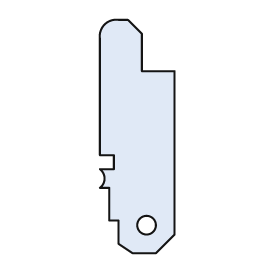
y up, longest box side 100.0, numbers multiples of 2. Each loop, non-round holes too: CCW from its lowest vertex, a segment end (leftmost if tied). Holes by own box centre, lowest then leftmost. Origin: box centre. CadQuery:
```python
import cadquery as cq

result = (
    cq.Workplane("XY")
    .moveTo(-2.0, -50.0)
    .lineTo(8.0, -50.0)
    .lineTo(16.0, -42.0)
    .lineTo(16.0, 28.0)
    .lineTo(2.0, 28.0)
    .lineTo(2.0, 44.0)
    .lineTo(-4.0, 50.0)
    .lineTo(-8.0, 50.0)
    .threePointArc((-14.0, 48.0), (-16.0, 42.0))
    .lineTo(-16.0, -8.0)
    .lineTo(-10.0, -8.0)
    .lineTo(-10.0, -14.0)
    .lineTo(-16.0, -14.0)
    .threePointArc((-14.0, -18.0), (-16.0, -22.0))
    .lineTo(-12.0, -22.0)
    .lineTo(-12.0, -36.0)
    .lineTo(-8.0, -36.0)
    .lineTo(-8.0, -46.0)
    .close()
    .moveTo(4.0, -38.0)
    .circle(4.0)
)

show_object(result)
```